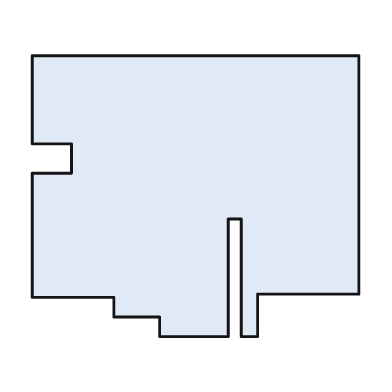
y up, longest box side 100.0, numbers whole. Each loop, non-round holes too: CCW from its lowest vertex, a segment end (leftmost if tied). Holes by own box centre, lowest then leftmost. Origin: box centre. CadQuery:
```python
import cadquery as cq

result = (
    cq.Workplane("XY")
    .moveTo(-11.0, -43.0)
    .lineTo(10.0, -43.0)
    .lineTo(10.0, -7.0)
    .lineTo(14.0, -7.0)
    .lineTo(14.0, -43.0)
    .lineTo(19.0, -43.0)
    .lineTo(19.0, -30.0)
    .lineTo(50.0, -30.0)
    .lineTo(50.0, 43.0)
    .lineTo(-50.0, 43.0)
    .lineTo(-50.0, 16.0)
    .lineTo(-38.0, 16.0)
    .lineTo(-38.0, 7.0)
    .lineTo(-50.0, 7.0)
    .lineTo(-50.0, -31.0)
    .lineTo(-25.0, -31.0)
    .lineTo(-25.0, -37.0)
    .lineTo(-11.0, -37.0)
    .close()
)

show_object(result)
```